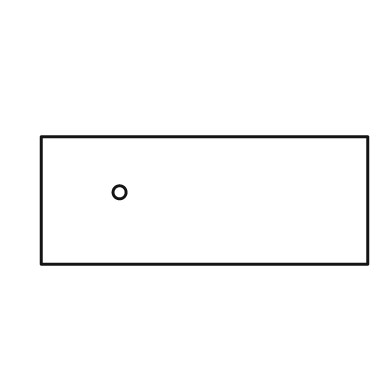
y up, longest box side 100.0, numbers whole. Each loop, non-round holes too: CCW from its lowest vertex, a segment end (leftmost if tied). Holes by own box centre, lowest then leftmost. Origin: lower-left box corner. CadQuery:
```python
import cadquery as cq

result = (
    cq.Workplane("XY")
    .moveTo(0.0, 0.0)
    .lineTo(100.0, 0.0)
    .lineTo(100.0, 39.0)
    .lineTo(0.0, 39.0)
    .close()
    .moveTo(24.0, 22.0)
    .circle(2.0)
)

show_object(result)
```